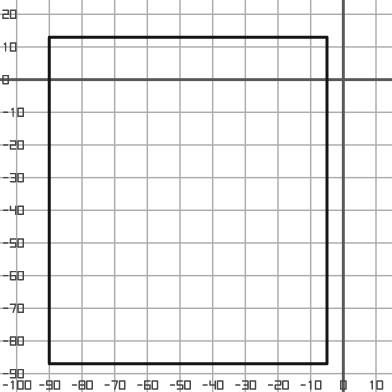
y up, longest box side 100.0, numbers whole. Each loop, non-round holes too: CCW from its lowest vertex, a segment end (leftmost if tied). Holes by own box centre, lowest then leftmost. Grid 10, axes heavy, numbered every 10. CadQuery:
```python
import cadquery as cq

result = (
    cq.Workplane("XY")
    .moveTo(-90.0, -87.0)
    .lineTo(-5.0, -87.0)
    .lineTo(-5.0, 13.0)
    .lineTo(-90.0, 13.0)
    .close()
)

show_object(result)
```